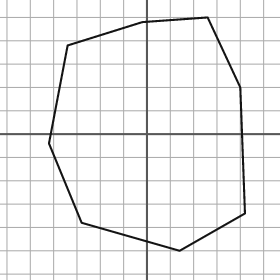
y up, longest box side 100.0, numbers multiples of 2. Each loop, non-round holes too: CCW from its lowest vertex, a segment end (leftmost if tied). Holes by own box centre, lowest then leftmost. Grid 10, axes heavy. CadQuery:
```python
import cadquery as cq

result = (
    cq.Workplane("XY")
    .moveTo(14.0, -50.0)
    .lineTo(42.0, -34.0)
    .lineTo(40.0, 20.0)
    .lineTo(26.0, 50.0)
    .lineTo(-2.0, 48.0)
    .lineTo(-34.0, 38.0)
    .lineTo(-42.0, -4.0)
    .lineTo(-28.0, -38.0)
    .close()
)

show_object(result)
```